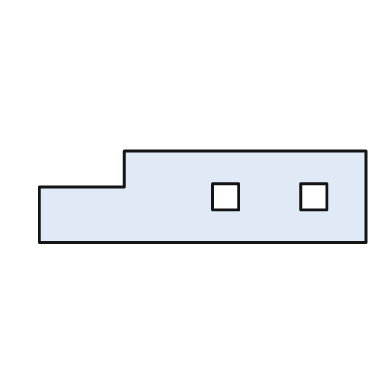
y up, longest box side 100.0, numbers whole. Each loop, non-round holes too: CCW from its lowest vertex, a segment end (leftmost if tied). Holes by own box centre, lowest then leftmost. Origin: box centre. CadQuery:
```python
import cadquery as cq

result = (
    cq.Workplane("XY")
    .moveTo(-50.0, -14.0)
    .lineTo(50.0, -14.0)
    .lineTo(50.0, 14.0)
    .lineTo(-24.0, 14.0)
    .lineTo(-24.0, 3.0)
    .lineTo(-50.0, 3.0)
    .close()
    .moveTo(3.0, -4.0)
    .lineTo(11.0, -4.0)
    .lineTo(11.0, 4.0)
    .lineTo(3.0, 4.0)
    .close()
    .moveTo(30.0, -4.0)
    .lineTo(38.0, -4.0)
    .lineTo(38.0, 4.0)
    .lineTo(30.0, 4.0)
    .close()
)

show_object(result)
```